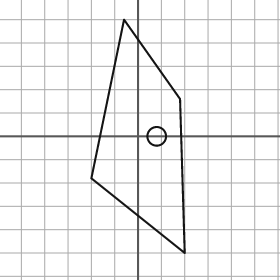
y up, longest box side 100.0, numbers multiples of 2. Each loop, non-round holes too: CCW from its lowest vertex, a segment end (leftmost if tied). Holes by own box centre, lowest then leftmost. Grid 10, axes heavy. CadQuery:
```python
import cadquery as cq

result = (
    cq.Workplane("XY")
    .moveTo(20.0, -50.0)
    .lineTo(18.0, 16.0)
    .lineTo(-6.0, 50.0)
    .lineTo(-20.0, -18.0)
    .close()
    .moveTo(8.0, 0.0)
    .circle(4.0)
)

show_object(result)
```